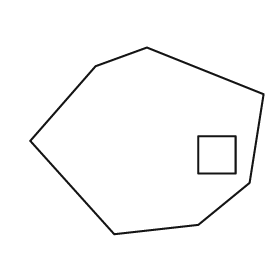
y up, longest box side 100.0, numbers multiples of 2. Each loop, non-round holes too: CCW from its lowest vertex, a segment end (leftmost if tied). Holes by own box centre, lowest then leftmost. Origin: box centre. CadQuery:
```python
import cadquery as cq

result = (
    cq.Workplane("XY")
    .moveTo(-14.0, -40.0)
    .lineTo(22.0, -36.0)
    .lineTo(44.0, -18.0)
    .lineTo(50.0, 20.0)
    .lineTo(0.0, 40.0)
    .lineTo(-22.0, 32.0)
    .lineTo(-50.0, 0.0)
    .close()
    .moveTo(22.0, -14.0)
    .lineTo(38.0, -14.0)
    .lineTo(38.0, 2.0)
    .lineTo(22.0, 2.0)
    .close()
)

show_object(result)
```